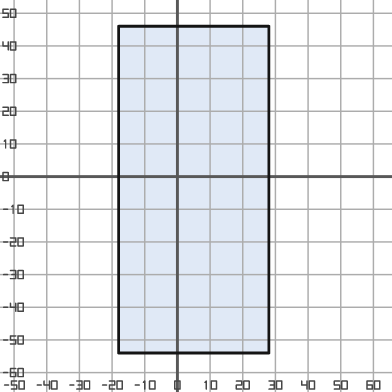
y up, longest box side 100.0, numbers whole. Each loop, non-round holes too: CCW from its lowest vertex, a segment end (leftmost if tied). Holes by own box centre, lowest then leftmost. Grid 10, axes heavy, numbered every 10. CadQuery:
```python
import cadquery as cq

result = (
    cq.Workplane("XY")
    .moveTo(-18.0, -54.0)
    .lineTo(28.0, -54.0)
    .lineTo(28.0, 46.0)
    .lineTo(-18.0, 46.0)
    .close()
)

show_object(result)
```